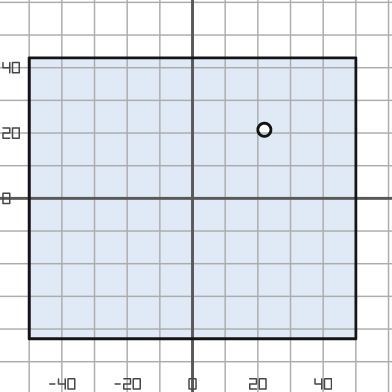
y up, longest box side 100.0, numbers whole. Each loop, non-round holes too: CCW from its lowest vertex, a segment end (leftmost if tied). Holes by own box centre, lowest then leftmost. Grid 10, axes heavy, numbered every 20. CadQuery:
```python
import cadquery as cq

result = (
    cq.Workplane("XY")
    .moveTo(-50.0, -43.0)
    .lineTo(50.0, -43.0)
    .lineTo(50.0, 43.0)
    .lineTo(-50.0, 43.0)
    .close()
    .moveTo(22.0, 21.0)
    .circle(2.0)
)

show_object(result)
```